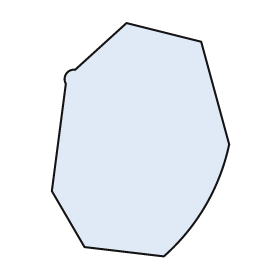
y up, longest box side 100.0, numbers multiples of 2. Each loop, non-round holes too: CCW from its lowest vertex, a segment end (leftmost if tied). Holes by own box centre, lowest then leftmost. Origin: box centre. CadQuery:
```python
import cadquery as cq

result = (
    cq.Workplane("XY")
    .moveTo(10.0, -50.0)
    .threePointArc((28.0, -28.0), (38.0, -2.0))
    .lineTo(26.0, 42.0)
    .lineTo(-6.0, 50.0)
    .lineTo(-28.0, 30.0)
    .threePointArc((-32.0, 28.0), (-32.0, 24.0))
    .lineTo(-38.0, -22.0)
    .lineTo(-24.0, -46.0)
    .close()
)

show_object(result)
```